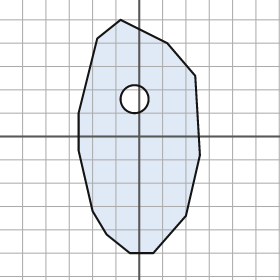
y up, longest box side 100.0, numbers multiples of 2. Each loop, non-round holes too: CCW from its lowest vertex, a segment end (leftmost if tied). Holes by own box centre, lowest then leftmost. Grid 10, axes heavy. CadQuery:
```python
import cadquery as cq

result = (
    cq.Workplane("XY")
    .moveTo(-4.0, -50.0)
    .lineTo(6.0, -50.0)
    .lineTo(20.0, -34.0)
    .lineTo(26.0, -8.0)
    .lineTo(24.0, 26.0)
    .lineTo(12.0, 40.0)
    .lineTo(-8.0, 50.0)
    .lineTo(-18.0, 42.0)
    .lineTo(-26.0, 10.0)
    .lineTo(-26.0, -6.0)
    .lineTo(-20.0, -32.0)
    .lineTo(-14.0, -42.0)
    .close()
    .moveTo(-2.0, 16.0)
    .circle(6.0)
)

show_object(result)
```